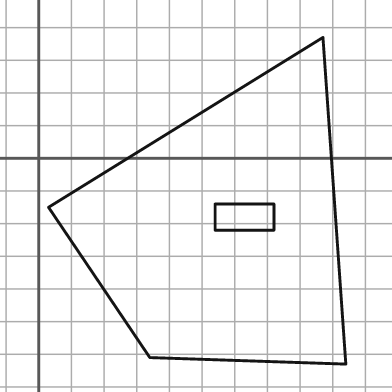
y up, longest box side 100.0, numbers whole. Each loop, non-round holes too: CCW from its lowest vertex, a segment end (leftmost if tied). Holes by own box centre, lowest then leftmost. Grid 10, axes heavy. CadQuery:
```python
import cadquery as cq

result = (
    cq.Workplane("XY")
    .moveTo(94.0, -63.0)
    .lineTo(87.0, 37.0)
    .lineTo(3.0, -15.0)
    .lineTo(34.0, -61.0)
    .close()
    .moveTo(54.0, -22.0)
    .lineTo(72.0, -22.0)
    .lineTo(72.0, -14.0)
    .lineTo(54.0, -14.0)
    .close()
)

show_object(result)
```